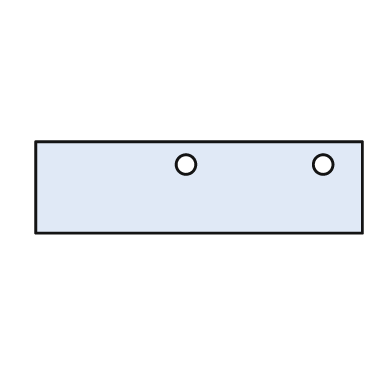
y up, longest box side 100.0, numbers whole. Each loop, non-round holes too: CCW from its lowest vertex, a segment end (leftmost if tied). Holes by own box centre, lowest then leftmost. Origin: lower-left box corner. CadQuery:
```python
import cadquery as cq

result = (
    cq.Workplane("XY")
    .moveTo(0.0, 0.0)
    .lineTo(100.0, 0.0)
    .lineTo(100.0, 28.0)
    .lineTo(0.0, 28.0)
    .close()
    .moveTo(46.0, 21.0)
    .circle(3.0)
    .moveTo(88.0, 21.0)
    .circle(3.0)
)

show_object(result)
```